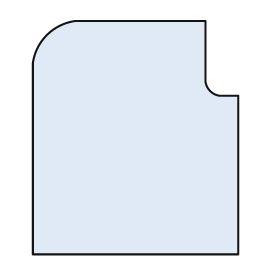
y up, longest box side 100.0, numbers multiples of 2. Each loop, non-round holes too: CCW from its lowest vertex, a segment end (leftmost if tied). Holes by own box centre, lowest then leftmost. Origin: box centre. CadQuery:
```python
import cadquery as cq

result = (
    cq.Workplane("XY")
    .moveTo(-44.0, -50.0)
    .lineTo(44.0, -50.0)
    .lineTo(44.0, 18.0)
    .lineTo(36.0, 18.0)
    .threePointArc((32.0, 20.0), (30.0, 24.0))
    .lineTo(30.0, 50.0)
    .lineTo(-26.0, 50.0)
    .threePointArc((-38.0, 44.0), (-44.0, 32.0))
    .close()
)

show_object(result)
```